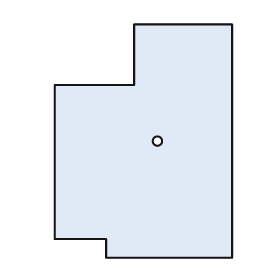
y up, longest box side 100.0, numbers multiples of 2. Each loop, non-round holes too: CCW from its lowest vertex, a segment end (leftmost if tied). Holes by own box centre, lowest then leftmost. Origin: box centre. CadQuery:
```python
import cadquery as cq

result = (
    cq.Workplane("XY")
    .moveTo(-16.0, -50.0)
    .lineTo(38.0, -50.0)
    .lineTo(38.0, 50.0)
    .lineTo(-4.0, 50.0)
    .lineTo(-4.0, 24.0)
    .lineTo(-38.0, 24.0)
    .lineTo(-38.0, -42.0)
    .lineTo(-16.0, -42.0)
    .close()
    .moveTo(6.0, 0.0)
    .circle(2.0)
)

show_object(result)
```